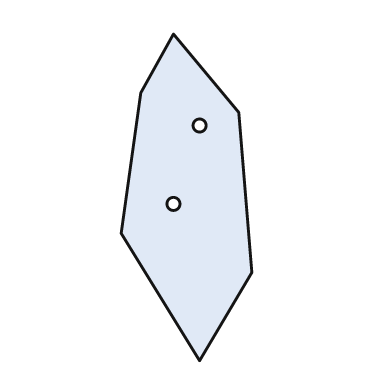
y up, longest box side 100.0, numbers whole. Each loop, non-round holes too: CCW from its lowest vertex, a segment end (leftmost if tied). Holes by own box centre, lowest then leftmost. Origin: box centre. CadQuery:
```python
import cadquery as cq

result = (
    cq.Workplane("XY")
    .moveTo(4.0, -50.0)
    .lineTo(20.0, -23.0)
    .lineTo(16.0, 26.0)
    .lineTo(-4.0, 50.0)
    .lineTo(-14.0, 32.0)
    .lineTo(-20.0, -11.0)
    .close()
    .moveTo(-4.0, -2.0)
    .circle(2.0)
    .moveTo(4.0, 22.0)
    .circle(2.0)
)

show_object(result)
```